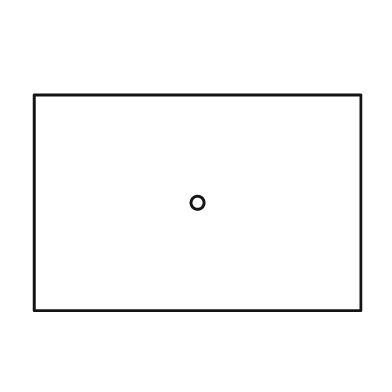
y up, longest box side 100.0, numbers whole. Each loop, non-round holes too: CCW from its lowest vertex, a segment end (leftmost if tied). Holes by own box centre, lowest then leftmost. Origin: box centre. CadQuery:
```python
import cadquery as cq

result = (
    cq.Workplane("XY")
    .moveTo(-50.0, -33.0)
    .lineTo(50.0, -33.0)
    .lineTo(50.0, 33.0)
    .lineTo(-50.0, 33.0)
    .close()
    .moveTo(0.0, 0.0)
    .circle(2.0)
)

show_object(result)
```